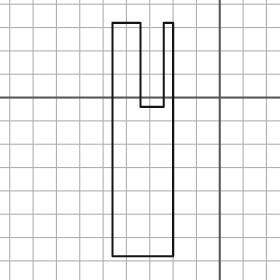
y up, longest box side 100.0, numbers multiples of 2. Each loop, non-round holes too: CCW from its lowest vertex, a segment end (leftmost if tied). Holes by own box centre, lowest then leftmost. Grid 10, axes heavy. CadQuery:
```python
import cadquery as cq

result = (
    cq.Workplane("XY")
    .moveTo(-46.0, -68.0)
    .lineTo(-20.0, -68.0)
    .lineTo(-20.0, 32.0)
    .lineTo(-24.0, 32.0)
    .lineTo(-24.0, -4.0)
    .lineTo(-34.0, -4.0)
    .lineTo(-34.0, 32.0)
    .lineTo(-46.0, 32.0)
    .close()
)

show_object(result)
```